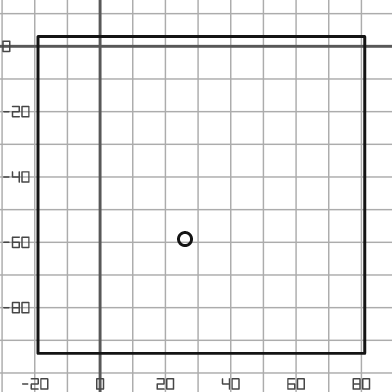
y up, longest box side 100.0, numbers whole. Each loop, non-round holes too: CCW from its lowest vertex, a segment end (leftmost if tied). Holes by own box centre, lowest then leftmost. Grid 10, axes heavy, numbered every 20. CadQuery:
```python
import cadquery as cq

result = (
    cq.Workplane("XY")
    .moveTo(-19.0, -94.0)
    .lineTo(81.0, -94.0)
    .lineTo(81.0, 3.0)
    .lineTo(-19.0, 3.0)
    .close()
    .moveTo(26.0, -59.0)
    .circle(2.0)
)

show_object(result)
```